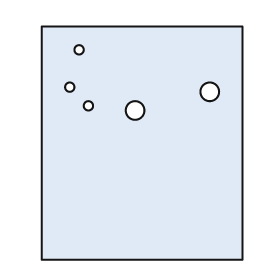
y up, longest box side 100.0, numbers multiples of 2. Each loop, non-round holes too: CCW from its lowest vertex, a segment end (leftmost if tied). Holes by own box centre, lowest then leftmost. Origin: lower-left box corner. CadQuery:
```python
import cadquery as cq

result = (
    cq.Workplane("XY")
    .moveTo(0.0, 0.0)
    .lineTo(86.0, 0.0)
    .lineTo(86.0, 100.0)
    .lineTo(0.0, 100.0)
    .close()
    .moveTo(40.0, 64.0)
    .circle(4.0)
    .moveTo(20.0, 66.0)
    .circle(2.0)
    .moveTo(72.0, 72.0)
    .circle(4.0)
    .moveTo(12.0, 74.0)
    .circle(2.0)
    .moveTo(16.0, 90.0)
    .circle(2.0)
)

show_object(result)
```